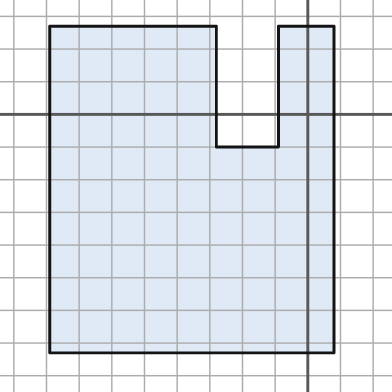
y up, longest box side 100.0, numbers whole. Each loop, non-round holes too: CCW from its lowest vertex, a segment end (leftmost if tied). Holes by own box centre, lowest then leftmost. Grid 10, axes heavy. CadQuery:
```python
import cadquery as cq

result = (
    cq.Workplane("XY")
    .moveTo(-79.0, -73.0)
    .lineTo(8.0, -73.0)
    .lineTo(8.0, 27.0)
    .lineTo(-9.0, 27.0)
    .lineTo(-9.0, -10.0)
    .lineTo(-28.0, -10.0)
    .lineTo(-28.0, 27.0)
    .lineTo(-79.0, 27.0)
    .close()
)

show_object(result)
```